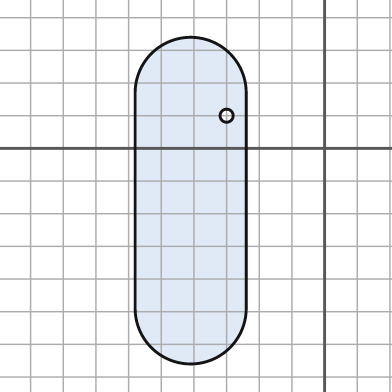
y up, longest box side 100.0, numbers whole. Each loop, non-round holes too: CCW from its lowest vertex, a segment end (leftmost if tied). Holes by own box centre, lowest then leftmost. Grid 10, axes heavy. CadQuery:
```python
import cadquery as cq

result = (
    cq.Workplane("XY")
    .moveTo(-58.0, -49.0)
    .threePointArc((-41.0, -66.0), (-24.0, -49.0))
    .lineTo(-24.0, 17.0)
    .threePointArc((-41.0, 34.0), (-58.0, 17.0))
    .close()
    .moveTo(-30.0, 10.0)
    .circle(2.0)
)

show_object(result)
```